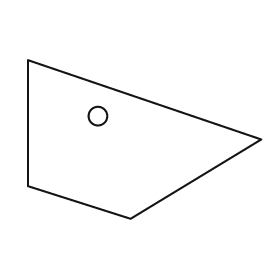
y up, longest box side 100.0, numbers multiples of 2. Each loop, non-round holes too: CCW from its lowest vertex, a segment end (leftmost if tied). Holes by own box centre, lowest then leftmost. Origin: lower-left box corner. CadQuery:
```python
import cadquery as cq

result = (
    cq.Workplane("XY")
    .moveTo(44.0, 0.0)
    .lineTo(100.0, 34.0)
    .lineTo(0.0, 68.0)
    .lineTo(0.0, 14.0)
    .close()
    .moveTo(30.0, 44.0)
    .circle(4.0)
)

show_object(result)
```